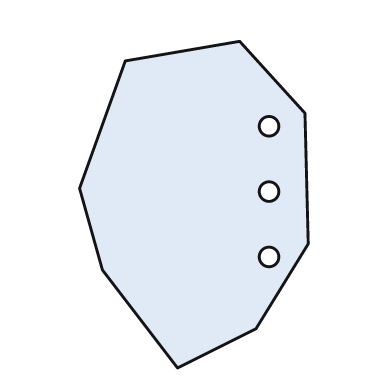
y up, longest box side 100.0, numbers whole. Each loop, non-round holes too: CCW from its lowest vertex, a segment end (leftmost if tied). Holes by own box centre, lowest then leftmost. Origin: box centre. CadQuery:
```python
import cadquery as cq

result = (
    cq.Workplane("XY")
    .moveTo(-5.0, -50.0)
    .lineTo(19.0, -38.0)
    .lineTo(35.0, -12.0)
    .lineTo(34.0, 28.0)
    .lineTo(14.0, 50.0)
    .lineTo(-21.0, 44.0)
    .lineTo(-35.0, 5.0)
    .lineTo(-28.0, -20.0)
    .close()
    .moveTo(23.0, -16.0)
    .circle(3.0)
    .moveTo(23.0, 4.0)
    .circle(3.0)
    .moveTo(23.0, 24.0)
    .circle(3.0)
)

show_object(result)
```